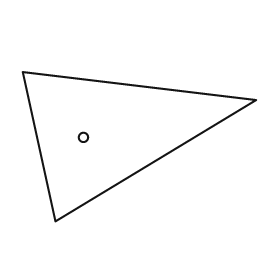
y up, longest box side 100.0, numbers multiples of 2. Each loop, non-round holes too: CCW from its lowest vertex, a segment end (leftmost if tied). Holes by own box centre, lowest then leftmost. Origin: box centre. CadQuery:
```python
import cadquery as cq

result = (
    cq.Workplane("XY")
    .moveTo(-36.0, -32.0)
    .lineTo(50.0, 20.0)
    .lineTo(-50.0, 32.0)
    .close()
    .moveTo(-24.0, 4.0)
    .circle(2.0)
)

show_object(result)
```